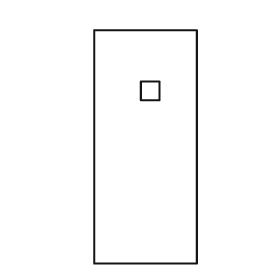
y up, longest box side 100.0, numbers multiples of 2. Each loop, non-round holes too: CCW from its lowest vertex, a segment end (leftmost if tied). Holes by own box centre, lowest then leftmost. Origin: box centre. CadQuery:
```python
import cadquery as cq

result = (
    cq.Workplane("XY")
    .moveTo(-22.0, -50.0)
    .lineTo(22.0, -50.0)
    .lineTo(22.0, 50.0)
    .lineTo(-22.0, 50.0)
    .close()
    .moveTo(-2.0, 20.0)
    .lineTo(6.0, 20.0)
    .lineTo(6.0, 28.0)
    .lineTo(-2.0, 28.0)
    .close()
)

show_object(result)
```